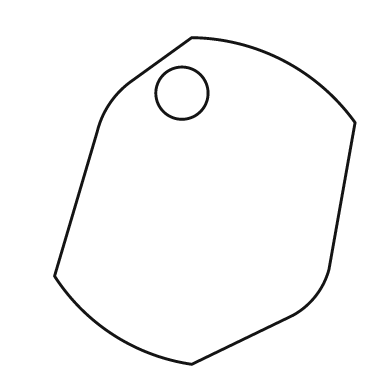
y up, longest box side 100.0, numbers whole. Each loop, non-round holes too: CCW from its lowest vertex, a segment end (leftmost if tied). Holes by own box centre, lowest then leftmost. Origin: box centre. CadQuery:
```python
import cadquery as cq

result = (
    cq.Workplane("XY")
    .moveTo(-4.0, -50.0)
    .lineTo(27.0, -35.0)
    .threePointArc((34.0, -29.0), (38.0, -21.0))
    .lineTo(46.0, 24.0)
    .threePointArc((24.0, 43.0), (-4.0, 50.0))
    .lineTo(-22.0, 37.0)
    .threePointArc((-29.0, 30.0), (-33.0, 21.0))
    .lineTo(-46.0, -23.0)
    .threePointArc((-28.0, -41.0), (-4.0, -50.0))
    .close()
    .moveTo(-7.0, 33.0)
    .circle(8.0)
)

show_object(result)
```